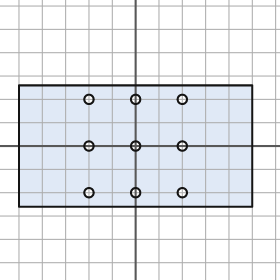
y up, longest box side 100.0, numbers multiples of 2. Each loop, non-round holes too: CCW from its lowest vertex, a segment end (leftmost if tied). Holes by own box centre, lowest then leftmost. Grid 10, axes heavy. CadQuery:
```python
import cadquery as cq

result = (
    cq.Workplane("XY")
    .moveTo(-50.0, -26.0)
    .lineTo(50.0, -26.0)
    .lineTo(50.0, 26.0)
    .lineTo(-50.0, 26.0)
    .close()
    .moveTo(-20.0, -20.0)
    .circle(2.0)
    .moveTo(0.0, -20.0)
    .circle(2.0)
    .moveTo(20.0, -20.0)
    .circle(2.0)
    .moveTo(-20.0, 0.0)
    .circle(2.0)
    .moveTo(0.0, 0.0)
    .circle(2.0)
    .moveTo(20.0, 0.0)
    .circle(2.0)
    .moveTo(-20.0, 20.0)
    .circle(2.0)
    .moveTo(0.0, 20.0)
    .circle(2.0)
    .moveTo(20.0, 20.0)
    .circle(2.0)
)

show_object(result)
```